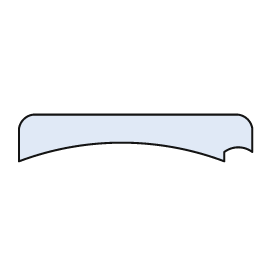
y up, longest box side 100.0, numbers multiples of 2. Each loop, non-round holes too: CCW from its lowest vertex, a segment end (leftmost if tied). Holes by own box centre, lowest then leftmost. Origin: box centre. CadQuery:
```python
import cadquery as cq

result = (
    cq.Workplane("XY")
    .moveTo(-50.0, -10.0)
    .threePointArc((-6.0, -2.0), (38.0, -10.0))
    .lineTo(38.0, -6.0)
    .threePointArc((44.0, -4.0), (50.0, -6.0))
    .lineTo(50.0, 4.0)
    .threePointArc((48.0, 8.0), (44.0, 10.0))
    .lineTo(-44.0, 10.0)
    .threePointArc((-48.0, 8.0), (-50.0, 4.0))
    .close()
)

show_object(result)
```